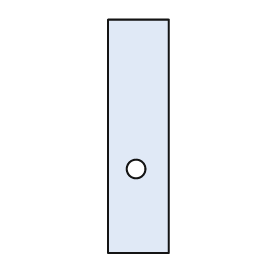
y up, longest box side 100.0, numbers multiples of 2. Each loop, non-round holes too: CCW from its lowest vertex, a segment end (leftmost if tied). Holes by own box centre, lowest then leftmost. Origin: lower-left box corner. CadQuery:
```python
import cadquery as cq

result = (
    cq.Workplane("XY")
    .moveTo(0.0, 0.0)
    .lineTo(26.0, 0.0)
    .lineTo(26.0, 100.0)
    .lineTo(0.0, 100.0)
    .close()
    .moveTo(12.0, 36.0)
    .circle(4.0)
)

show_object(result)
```